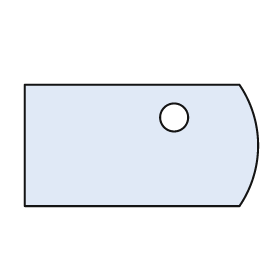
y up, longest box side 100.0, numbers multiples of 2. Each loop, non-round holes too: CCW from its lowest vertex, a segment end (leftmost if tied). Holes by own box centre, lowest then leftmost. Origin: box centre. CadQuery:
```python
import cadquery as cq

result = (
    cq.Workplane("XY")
    .moveTo(-50.0, -26.0)
    .lineTo(42.0, -26.0)
    .threePointArc((50.0, 0.0), (42.0, 26.0))
    .lineTo(-50.0, 26.0)
    .close()
    .moveTo(14.0, 12.0)
    .circle(6.0)
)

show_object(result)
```